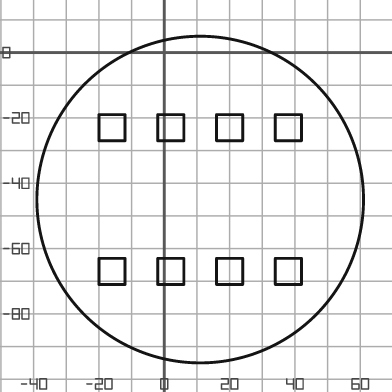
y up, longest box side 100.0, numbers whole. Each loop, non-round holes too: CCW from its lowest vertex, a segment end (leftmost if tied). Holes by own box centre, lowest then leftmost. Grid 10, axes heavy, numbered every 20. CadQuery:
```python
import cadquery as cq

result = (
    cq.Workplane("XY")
    .moveTo(11.0, -45.0)
    .circle(50.0)
    .moveTo(-20.0, -71.0)
    .lineTo(-12.0, -71.0)
    .lineTo(-12.0, -63.0)
    .lineTo(-20.0, -63.0)
    .close()
    .moveTo(-2.0, -71.0)
    .lineTo(6.0, -71.0)
    .lineTo(6.0, -63.0)
    .lineTo(-2.0, -63.0)
    .close()
    .moveTo(16.0, -71.0)
    .lineTo(24.0, -71.0)
    .lineTo(24.0, -63.0)
    .lineTo(16.0, -63.0)
    .close()
    .moveTo(34.0, -71.0)
    .lineTo(42.0, -71.0)
    .lineTo(42.0, -63.0)
    .lineTo(34.0, -63.0)
    .close()
    .moveTo(-20.0, -27.0)
    .lineTo(-12.0, -27.0)
    .lineTo(-12.0, -19.0)
    .lineTo(-20.0, -19.0)
    .close()
    .moveTo(-2.0, -27.0)
    .lineTo(6.0, -27.0)
    .lineTo(6.0, -19.0)
    .lineTo(-2.0, -19.0)
    .close()
    .moveTo(16.0, -27.0)
    .lineTo(24.0, -27.0)
    .lineTo(24.0, -19.0)
    .lineTo(16.0, -19.0)
    .close()
    .moveTo(34.0, -27.0)
    .lineTo(42.0, -27.0)
    .lineTo(42.0, -19.0)
    .lineTo(34.0, -19.0)
    .close()
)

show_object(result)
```